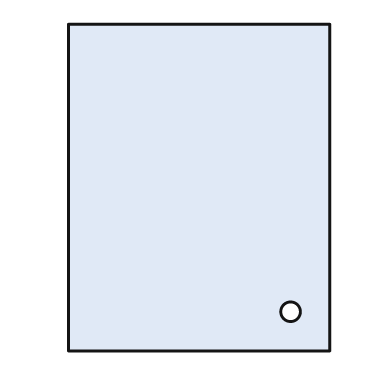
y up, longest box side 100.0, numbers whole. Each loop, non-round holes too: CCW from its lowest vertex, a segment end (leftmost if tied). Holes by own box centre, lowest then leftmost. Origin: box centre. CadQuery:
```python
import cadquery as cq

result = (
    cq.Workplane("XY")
    .moveTo(-40.0, -50.0)
    .lineTo(40.0, -50.0)
    .lineTo(40.0, 50.0)
    .lineTo(-40.0, 50.0)
    .close()
    .moveTo(28.0, -38.0)
    .circle(3.0)
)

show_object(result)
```